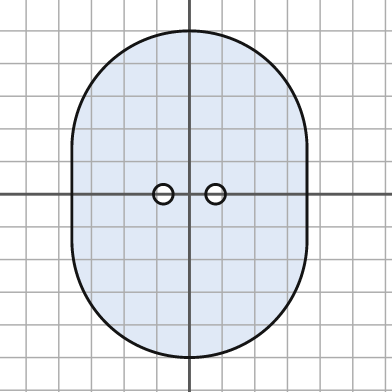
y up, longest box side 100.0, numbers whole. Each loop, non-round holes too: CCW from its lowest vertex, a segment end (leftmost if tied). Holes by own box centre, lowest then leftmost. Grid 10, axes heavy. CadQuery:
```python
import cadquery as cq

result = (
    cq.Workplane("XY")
    .moveTo(-36.0, -14.0)
    .threePointArc((0.0, -50.0), (36.0, -14.0))
    .lineTo(36.0, 14.0)
    .threePointArc((0.0, 50.0), (-36.0, 14.0))
    .close()
    .moveTo(-8.0, 0.0)
    .circle(3.0)
    .moveTo(8.0, 0.0)
    .circle(3.0)
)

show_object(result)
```